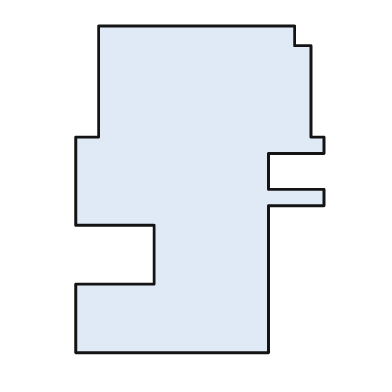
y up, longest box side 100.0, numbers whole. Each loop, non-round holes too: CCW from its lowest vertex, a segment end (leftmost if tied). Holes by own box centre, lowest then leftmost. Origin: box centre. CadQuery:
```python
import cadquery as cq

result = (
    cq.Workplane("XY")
    .moveTo(-38.0, -50.0)
    .lineTo(21.0, -50.0)
    .lineTo(21.0, -5.0)
    .lineTo(38.0, -5.0)
    .lineTo(38.0, 0.0)
    .lineTo(21.0, 0.0)
    .lineTo(21.0, 11.0)
    .lineTo(38.0, 11.0)
    .lineTo(38.0, 16.0)
    .lineTo(34.0, 16.0)
    .lineTo(34.0, 44.0)
    .lineTo(29.0, 44.0)
    .lineTo(29.0, 50.0)
    .lineTo(-31.0, 50.0)
    .lineTo(-31.0, 16.0)
    .lineTo(-38.0, 16.0)
    .lineTo(-38.0, -11.0)
    .lineTo(-14.0, -11.0)
    .lineTo(-14.0, -29.0)
    .lineTo(-38.0, -29.0)
    .close()
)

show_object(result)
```